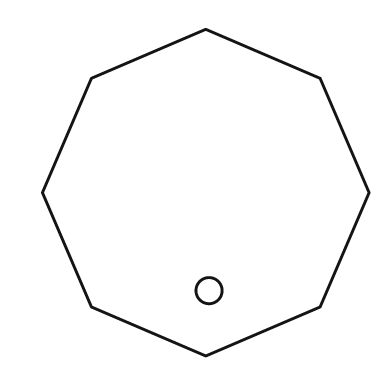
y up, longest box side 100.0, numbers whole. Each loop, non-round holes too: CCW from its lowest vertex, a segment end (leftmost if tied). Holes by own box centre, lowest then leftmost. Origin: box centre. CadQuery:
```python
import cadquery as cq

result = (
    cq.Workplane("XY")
    .moveTo(0.0, -50.0)
    .lineTo(35.0, -35.0)
    .lineTo(50.0, 0.0)
    .lineTo(35.0, 35.0)
    .lineTo(0.0, 50.0)
    .lineTo(-35.0, 35.0)
    .lineTo(-50.0, 0.0)
    .lineTo(-35.0, -35.0)
    .close()
    .moveTo(1.0, -30.0)
    .circle(4.0)
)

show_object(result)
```